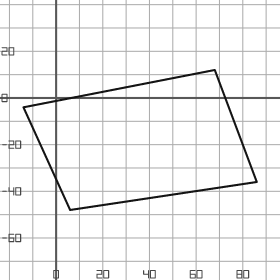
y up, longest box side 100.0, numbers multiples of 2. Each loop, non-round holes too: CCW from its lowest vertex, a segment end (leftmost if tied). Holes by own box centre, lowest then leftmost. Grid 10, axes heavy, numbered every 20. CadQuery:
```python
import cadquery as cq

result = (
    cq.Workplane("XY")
    .moveTo(6.0, -48.0)
    .lineTo(86.0, -36.0)
    .lineTo(68.0, 12.0)
    .lineTo(-14.0, -4.0)
    .close()
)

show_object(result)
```